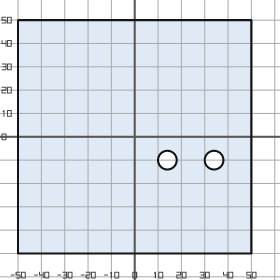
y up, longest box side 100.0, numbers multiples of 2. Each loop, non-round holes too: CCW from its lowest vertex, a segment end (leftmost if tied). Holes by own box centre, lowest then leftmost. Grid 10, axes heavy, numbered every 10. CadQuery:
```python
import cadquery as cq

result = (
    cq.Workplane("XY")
    .moveTo(-50.0, -50.0)
    .lineTo(50.0, -50.0)
    .lineTo(50.0, 50.0)
    .lineTo(-50.0, 50.0)
    .close()
    .moveTo(14.0, -10.0)
    .circle(4.0)
    .moveTo(34.0, -10.0)
    .circle(4.0)
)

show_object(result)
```